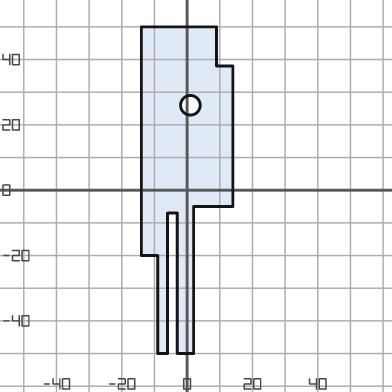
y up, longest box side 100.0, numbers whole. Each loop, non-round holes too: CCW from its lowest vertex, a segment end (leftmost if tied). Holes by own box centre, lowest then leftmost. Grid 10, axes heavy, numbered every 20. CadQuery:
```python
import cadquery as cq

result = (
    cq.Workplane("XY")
    .moveTo(-9.0, -50.0)
    .lineTo(-6.0, -50.0)
    .lineTo(-6.0, -7.0)
    .lineTo(-3.0, -7.0)
    .lineTo(-3.0, -50.0)
    .lineTo(2.0, -50.0)
    .lineTo(2.0, -5.0)
    .lineTo(14.0, -5.0)
    .lineTo(14.0, 38.0)
    .lineTo(9.0, 38.0)
    .lineTo(9.0, 50.0)
    .lineTo(-14.0, 50.0)
    .lineTo(-14.0, -20.0)
    .lineTo(-9.0, -20.0)
    .close()
    .moveTo(1.0, 26.0)
    .circle(3.0)
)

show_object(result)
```